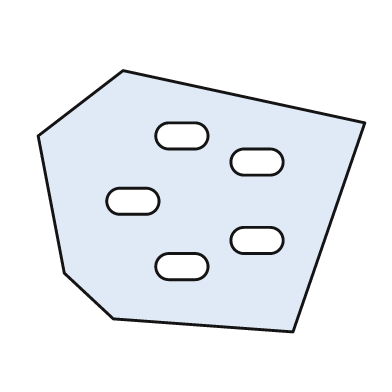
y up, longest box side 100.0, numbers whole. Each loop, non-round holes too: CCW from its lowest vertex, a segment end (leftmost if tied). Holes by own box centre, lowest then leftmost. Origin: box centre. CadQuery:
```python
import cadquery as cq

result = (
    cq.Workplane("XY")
    .moveTo(28.0, -40.0)
    .lineTo(50.0, 24.0)
    .lineTo(-24.0, 40.0)
    .lineTo(-50.0, 20.0)
    .lineTo(-42.0, -22.0)
    .lineTo(-27.0, -36.0)
    .close()
    .moveTo(-10.0, -24.0)
    .lineTo(-2.0, -24.0)
    .threePointArc((2.0, -20.0), (-2.0, -16.0))
    .lineTo(-10.0, -16.0)
    .threePointArc((-14.0, -20.0), (-10.0, -24.0))
    .close()
    .moveTo(13.0, -16.0)
    .lineTo(21.0, -16.0)
    .threePointArc((25.0, -12.0), (21.0, -8.0))
    .lineTo(13.0, -8.0)
    .threePointArc((9.0, -12.0), (13.0, -16.0))
    .close()
    .moveTo(-25.0, -4.0)
    .lineTo(-17.0, -4.0)
    .threePointArc((-13.0, 0.0), (-17.0, 4.0))
    .lineTo(-25.0, 4.0)
    .threePointArc((-29.0, 0.0), (-25.0, -4.0))
    .close()
    .moveTo(13.0, 8.0)
    .lineTo(21.0, 8.0)
    .threePointArc((25.0, 12.0), (21.0, 16.0))
    .lineTo(13.0, 16.0)
    .threePointArc((9.0, 12.0), (13.0, 8.0))
    .close()
    .moveTo(-10.0, 16.0)
    .lineTo(-2.0, 16.0)
    .threePointArc((2.0, 20.0), (-2.0, 24.0))
    .lineTo(-10.0, 24.0)
    .threePointArc((-14.0, 20.0), (-10.0, 16.0))
    .close()
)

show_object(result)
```